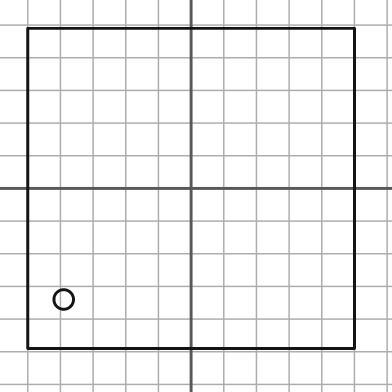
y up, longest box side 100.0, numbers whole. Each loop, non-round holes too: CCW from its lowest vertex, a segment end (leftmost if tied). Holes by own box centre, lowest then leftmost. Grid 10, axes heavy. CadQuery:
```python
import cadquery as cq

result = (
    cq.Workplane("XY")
    .moveTo(-50.0, -49.0)
    .lineTo(50.0, -49.0)
    .lineTo(50.0, 49.0)
    .lineTo(-50.0, 49.0)
    .close()
    .moveTo(-39.0, -34.0)
    .circle(3.0)
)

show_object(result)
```